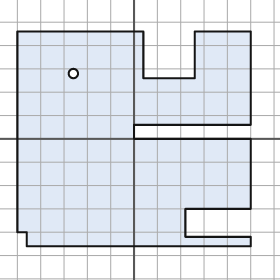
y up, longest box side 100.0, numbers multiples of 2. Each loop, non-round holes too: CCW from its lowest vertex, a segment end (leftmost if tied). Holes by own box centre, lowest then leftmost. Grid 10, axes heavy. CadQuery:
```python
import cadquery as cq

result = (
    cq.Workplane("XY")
    .moveTo(-46.0, -46.0)
    .lineTo(50.0, -46.0)
    .lineTo(50.0, -42.0)
    .lineTo(22.0, -42.0)
    .lineTo(22.0, -30.0)
    .lineTo(50.0, -30.0)
    .lineTo(50.0, 0.0)
    .lineTo(0.0, 0.0)
    .lineTo(0.0, 6.0)
    .lineTo(50.0, 6.0)
    .lineTo(50.0, 46.0)
    .lineTo(26.0, 46.0)
    .lineTo(26.0, 26.0)
    .lineTo(4.0, 26.0)
    .lineTo(4.0, 46.0)
    .lineTo(-50.0, 46.0)
    .lineTo(-50.0, -40.0)
    .lineTo(-46.0, -40.0)
    .close()
    .moveTo(-26.0, 28.0)
    .circle(2.0)
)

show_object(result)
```